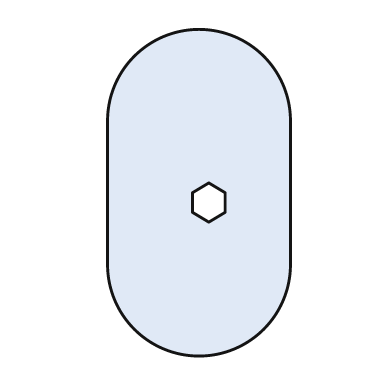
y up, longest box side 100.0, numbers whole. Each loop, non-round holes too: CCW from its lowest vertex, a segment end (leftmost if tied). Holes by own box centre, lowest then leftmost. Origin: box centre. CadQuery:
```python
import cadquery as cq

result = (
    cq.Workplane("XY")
    .moveTo(-28.0, -22.0)
    .threePointArc((0.0, -50.0), (28.0, -22.0))
    .lineTo(28.0, 22.0)
    .threePointArc((0.0, 50.0), (-28.0, 22.0))
    .close()
    .moveTo(3.0, -9.0)
    .lineTo(8.0, -6.0)
    .lineTo(8.0, 0.0)
    .lineTo(3.0, 3.0)
    .lineTo(-2.0, 0.0)
    .lineTo(-2.0, -6.0)
    .close()
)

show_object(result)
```